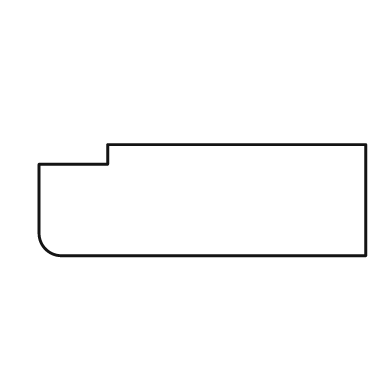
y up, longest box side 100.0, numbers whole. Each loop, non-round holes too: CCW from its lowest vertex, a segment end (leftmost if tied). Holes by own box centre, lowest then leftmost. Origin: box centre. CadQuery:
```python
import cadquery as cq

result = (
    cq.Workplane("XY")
    .moveTo(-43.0, -17.0)
    .lineTo(50.0, -17.0)
    .lineTo(50.0, 17.0)
    .lineTo(-29.0, 17.0)
    .lineTo(-29.0, 11.0)
    .lineTo(-50.0, 11.0)
    .lineTo(-50.0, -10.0)
    .threePointArc((-48.0, -15.0), (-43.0, -17.0))
    .close()
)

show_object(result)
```